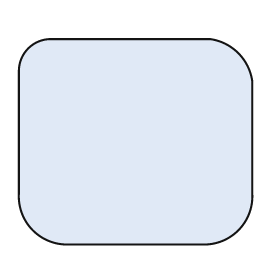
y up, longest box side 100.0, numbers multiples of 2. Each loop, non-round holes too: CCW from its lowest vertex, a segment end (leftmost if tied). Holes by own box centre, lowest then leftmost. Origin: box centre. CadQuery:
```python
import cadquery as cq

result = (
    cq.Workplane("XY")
    .moveTo(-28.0, -44.0)
    .lineTo(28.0, -44.0)
    .threePointArc((44.0, -38.0), (50.0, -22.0))
    .lineTo(50.0, 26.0)
    .threePointArc((44.0, 38.0), (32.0, 44.0))
    .lineTo(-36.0, 44.0)
    .threePointArc((-46.0, 40.0), (-50.0, 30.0))
    .lineTo(-50.0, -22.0)
    .threePointArc((-44.0, -38.0), (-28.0, -44.0))
    .close()
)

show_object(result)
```